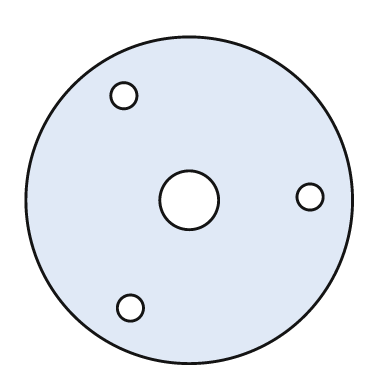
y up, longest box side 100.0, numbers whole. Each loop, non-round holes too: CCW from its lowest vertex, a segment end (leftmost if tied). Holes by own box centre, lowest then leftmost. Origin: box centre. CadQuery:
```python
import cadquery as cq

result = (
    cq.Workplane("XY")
    .moveTo(0.0, 0.0)
    .circle(50.0)
    .moveTo(-18.0, -33.0)
    .circle(4.0)
    .moveTo(0.0, 0.0)
    .circle(9.0)
    .moveTo(37.0, 1.0)
    .circle(4.0)
    .moveTo(-20.0, 32.0)
    .circle(4.0)
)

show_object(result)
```